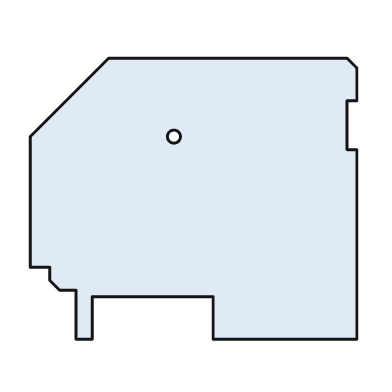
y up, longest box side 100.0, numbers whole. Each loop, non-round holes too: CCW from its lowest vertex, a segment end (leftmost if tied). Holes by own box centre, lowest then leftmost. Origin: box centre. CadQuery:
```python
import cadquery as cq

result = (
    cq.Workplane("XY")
    .moveTo(-36.0, -43.0)
    .lineTo(-31.0, -43.0)
    .lineTo(-31.0, -30.0)
    .lineTo(6.0, -30.0)
    .lineTo(6.0, -43.0)
    .lineTo(50.0, -43.0)
    .lineTo(50.0, 15.0)
    .lineTo(47.0, 15.0)
    .lineTo(47.0, 30.0)
    .lineTo(50.0, 30.0)
    .lineTo(50.0, 40.0)
    .lineTo(47.0, 43.0)
    .lineTo(-26.0, 43.0)
    .lineTo(-50.0, 19.0)
    .lineTo(-50.0, -21.0)
    .lineTo(-44.0, -21.0)
    .lineTo(-44.0, -25.0)
    .lineTo(-41.0, -28.0)
    .lineTo(-36.0, -28.0)
    .close()
    .moveTo(-6.0, 19.0)
    .circle(2.0)
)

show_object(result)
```